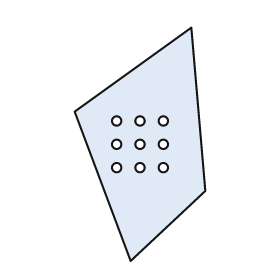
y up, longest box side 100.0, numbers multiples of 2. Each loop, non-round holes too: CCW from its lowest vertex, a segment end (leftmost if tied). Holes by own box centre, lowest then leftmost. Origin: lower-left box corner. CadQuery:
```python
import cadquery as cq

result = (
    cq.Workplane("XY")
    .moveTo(24.0, 0.0)
    .lineTo(56.0, 30.0)
    .lineTo(50.0, 100.0)
    .lineTo(0.0, 64.0)
    .close()
    .moveTo(18.0, 40.0)
    .circle(2.0)
    .moveTo(28.0, 40.0)
    .circle(2.0)
    .moveTo(38.0, 40.0)
    .circle(2.0)
    .moveTo(18.0, 50.0)
    .circle(2.0)
    .moveTo(28.0, 50.0)
    .circle(2.0)
    .moveTo(38.0, 50.0)
    .circle(2.0)
    .moveTo(18.0, 60.0)
    .circle(2.0)
    .moveTo(28.0, 60.0)
    .circle(2.0)
    .moveTo(38.0, 60.0)
    .circle(2.0)
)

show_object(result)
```